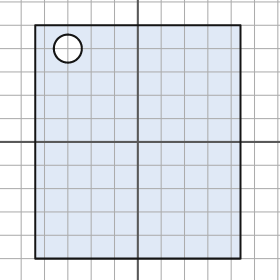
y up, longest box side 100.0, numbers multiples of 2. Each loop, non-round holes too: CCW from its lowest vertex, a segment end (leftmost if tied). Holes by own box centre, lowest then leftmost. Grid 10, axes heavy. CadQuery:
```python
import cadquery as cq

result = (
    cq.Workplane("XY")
    .moveTo(-44.0, -50.0)
    .lineTo(44.0, -50.0)
    .lineTo(44.0, 50.0)
    .lineTo(-44.0, 50.0)
    .close()
    .moveTo(-30.0, 40.0)
    .circle(6.0)
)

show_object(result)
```